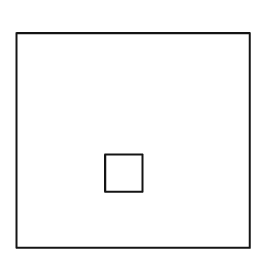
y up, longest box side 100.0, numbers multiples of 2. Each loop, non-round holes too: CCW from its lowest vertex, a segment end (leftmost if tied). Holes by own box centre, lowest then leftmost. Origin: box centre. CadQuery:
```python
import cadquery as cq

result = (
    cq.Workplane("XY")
    .moveTo(-50.0, -46.0)
    .lineTo(50.0, -46.0)
    .lineTo(50.0, 46.0)
    .lineTo(-50.0, 46.0)
    .close()
    .moveTo(-12.0, -22.0)
    .lineTo(4.0, -22.0)
    .lineTo(4.0, -6.0)
    .lineTo(-12.0, -6.0)
    .close()
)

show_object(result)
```